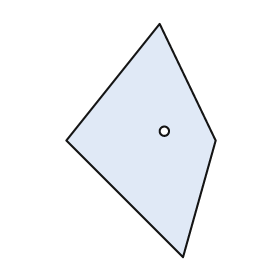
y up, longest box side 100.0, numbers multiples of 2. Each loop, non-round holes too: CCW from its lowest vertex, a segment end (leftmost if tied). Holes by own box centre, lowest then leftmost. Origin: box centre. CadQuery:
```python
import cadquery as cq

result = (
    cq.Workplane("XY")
    .moveTo(18.0, -50.0)
    .lineTo(32.0, 0.0)
    .lineTo(8.0, 50.0)
    .lineTo(-32.0, 0.0)
    .close()
    .moveTo(10.0, 4.0)
    .circle(2.0)
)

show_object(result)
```